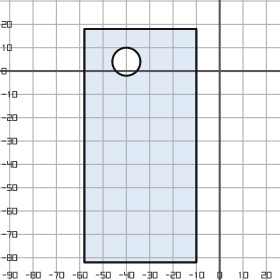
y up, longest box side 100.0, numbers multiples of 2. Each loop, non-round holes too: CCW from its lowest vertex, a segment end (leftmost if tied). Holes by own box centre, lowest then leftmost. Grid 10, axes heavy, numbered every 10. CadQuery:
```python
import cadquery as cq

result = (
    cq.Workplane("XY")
    .moveTo(-58.0, -82.0)
    .lineTo(-10.0, -82.0)
    .lineTo(-10.0, 18.0)
    .lineTo(-58.0, 18.0)
    .close()
    .moveTo(-40.0, 4.0)
    .circle(6.0)
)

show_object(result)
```